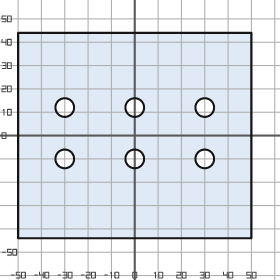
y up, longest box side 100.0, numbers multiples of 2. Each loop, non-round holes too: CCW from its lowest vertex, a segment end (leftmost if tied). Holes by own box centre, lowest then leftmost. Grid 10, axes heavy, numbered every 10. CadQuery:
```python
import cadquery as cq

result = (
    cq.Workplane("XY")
    .moveTo(-50.0, -44.0)
    .lineTo(50.0, -44.0)
    .lineTo(50.0, 44.0)
    .lineTo(-50.0, 44.0)
    .close()
    .moveTo(-30.0, -10.0)
    .circle(4.0)
    .moveTo(0.0, -10.0)
    .circle(4.0)
    .moveTo(30.0, -10.0)
    .circle(4.0)
    .moveTo(-30.0, 12.0)
    .circle(4.0)
    .moveTo(0.0, 12.0)
    .circle(4.0)
    .moveTo(30.0, 12.0)
    .circle(4.0)
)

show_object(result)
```